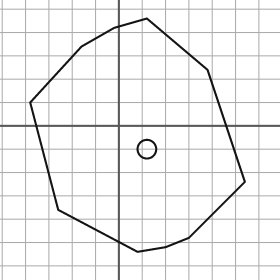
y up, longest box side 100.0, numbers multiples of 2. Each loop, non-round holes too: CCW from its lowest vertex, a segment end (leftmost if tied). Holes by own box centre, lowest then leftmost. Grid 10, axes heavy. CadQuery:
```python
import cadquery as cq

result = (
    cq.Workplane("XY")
    .moveTo(8.0, -54.0)
    .lineTo(20.0, -52.0)
    .lineTo(30.0, -48.0)
    .lineTo(54.0, -24.0)
    .lineTo(38.0, 24.0)
    .lineTo(12.0, 46.0)
    .lineTo(-2.0, 42.0)
    .lineTo(-16.0, 34.0)
    .lineTo(-38.0, 10.0)
    .lineTo(-26.0, -36.0)
    .close()
    .moveTo(12.0, -10.0)
    .circle(4.0)
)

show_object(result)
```